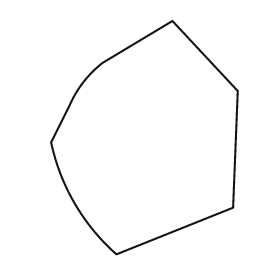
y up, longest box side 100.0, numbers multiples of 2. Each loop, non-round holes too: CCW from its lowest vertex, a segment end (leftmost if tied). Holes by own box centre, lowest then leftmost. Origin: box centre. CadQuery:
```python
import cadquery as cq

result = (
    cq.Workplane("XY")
    .moveTo(-12.0, -50.0)
    .lineTo(38.0, -30.0)
    .lineTo(40.0, 20.0)
    .lineTo(12.0, 50.0)
    .lineTo(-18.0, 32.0)
    .threePointArc((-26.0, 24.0), (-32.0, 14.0))
    .lineTo(-40.0, -2.0)
    .threePointArc((-30.0, -28.0), (-12.0, -50.0))
    .close()
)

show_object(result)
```